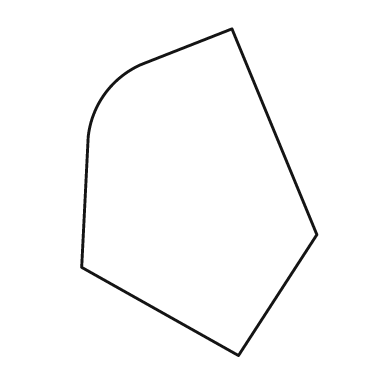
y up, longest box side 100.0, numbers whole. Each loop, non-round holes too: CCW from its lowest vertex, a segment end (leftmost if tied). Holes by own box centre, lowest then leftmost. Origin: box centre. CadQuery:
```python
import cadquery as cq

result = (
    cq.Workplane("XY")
    .moveTo(12.0, -50.0)
    .lineTo(36.0, -13.0)
    .lineTo(10.0, 50.0)
    .lineTo(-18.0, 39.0)
    .threePointArc((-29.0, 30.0), (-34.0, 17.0))
    .lineTo(-36.0, -23.0)
    .close()
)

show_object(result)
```